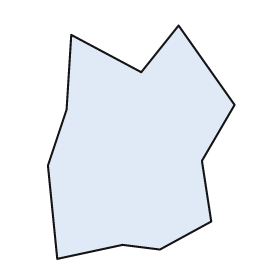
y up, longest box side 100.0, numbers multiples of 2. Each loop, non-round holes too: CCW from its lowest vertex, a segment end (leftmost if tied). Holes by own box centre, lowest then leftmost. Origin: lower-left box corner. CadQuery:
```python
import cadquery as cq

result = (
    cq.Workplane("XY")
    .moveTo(4.0, 0.0)
    .lineTo(32.0, 6.0)
    .lineTo(48.0, 4.0)
    .lineTo(70.0, 16.0)
    .lineTo(66.0, 42.0)
    .lineTo(80.0, 66.0)
    .lineTo(56.0, 100.0)
    .lineTo(40.0, 80.0)
    .lineTo(10.0, 96.0)
    .lineTo(8.0, 64.0)
    .lineTo(0.0, 40.0)
    .close()
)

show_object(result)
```